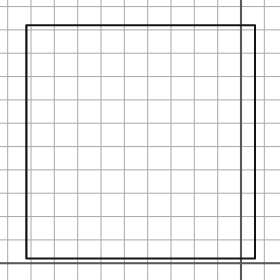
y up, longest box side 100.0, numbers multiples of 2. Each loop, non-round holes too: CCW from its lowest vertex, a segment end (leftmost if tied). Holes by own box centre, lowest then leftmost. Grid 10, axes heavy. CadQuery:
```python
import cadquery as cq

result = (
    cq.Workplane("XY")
    .moveTo(-92.0, 2.0)
    .lineTo(6.0, 2.0)
    .lineTo(6.0, 102.0)
    .lineTo(-92.0, 102.0)
    .close()
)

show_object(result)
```